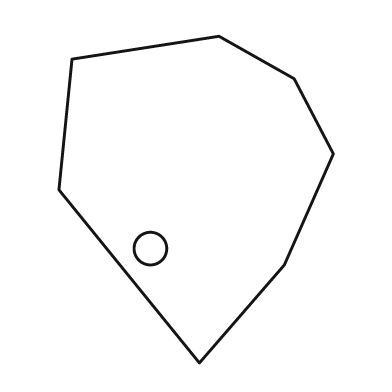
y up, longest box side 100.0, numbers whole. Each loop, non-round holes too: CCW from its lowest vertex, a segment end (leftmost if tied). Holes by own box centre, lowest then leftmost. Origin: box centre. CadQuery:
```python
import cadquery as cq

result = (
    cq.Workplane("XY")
    .moveTo(1.0, -50.0)
    .lineTo(27.0, -20.0)
    .lineTo(42.0, 14.0)
    .lineTo(30.0, 37.0)
    .lineTo(7.0, 50.0)
    .lineTo(-38.0, 43.0)
    .lineTo(-42.0, 3.0)
    .close()
    .moveTo(-14.0, -15.0)
    .circle(5.0)
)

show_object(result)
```